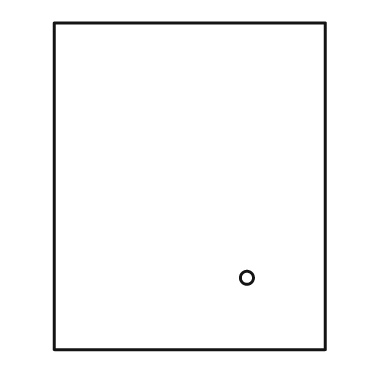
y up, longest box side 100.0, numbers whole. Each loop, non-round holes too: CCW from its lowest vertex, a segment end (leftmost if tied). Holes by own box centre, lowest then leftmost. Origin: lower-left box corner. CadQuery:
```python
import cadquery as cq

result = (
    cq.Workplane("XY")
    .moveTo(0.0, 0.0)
    .lineTo(83.0, 0.0)
    .lineTo(83.0, 100.0)
    .lineTo(0.0, 100.0)
    .close()
    .moveTo(59.0, 22.0)
    .circle(2.0)
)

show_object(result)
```